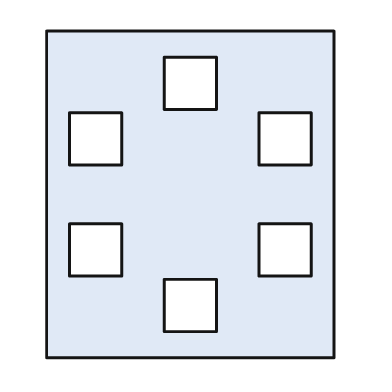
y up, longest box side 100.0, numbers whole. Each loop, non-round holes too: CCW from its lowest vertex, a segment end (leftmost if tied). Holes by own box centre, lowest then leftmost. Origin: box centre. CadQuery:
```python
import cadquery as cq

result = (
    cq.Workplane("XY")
    .moveTo(-44.0, -50.0)
    .lineTo(44.0, -50.0)
    .lineTo(44.0, 50.0)
    .lineTo(-44.0, 50.0)
    .close()
    .moveTo(-8.0, -42.0)
    .lineTo(8.0, -42.0)
    .lineTo(8.0, -26.0)
    .lineTo(-8.0, -26.0)
    .close()
    .moveTo(-37.0, -25.0)
    .lineTo(-21.0, -25.0)
    .lineTo(-21.0, -9.0)
    .lineTo(-37.0, -9.0)
    .close()
    .moveTo(21.0, -25.0)
    .lineTo(37.0, -25.0)
    .lineTo(37.0, -9.0)
    .lineTo(21.0, -9.0)
    .close()
    .moveTo(-37.0, 9.0)
    .lineTo(-21.0, 9.0)
    .lineTo(-21.0, 25.0)
    .lineTo(-37.0, 25.0)
    .close()
    .moveTo(21.0, 9.0)
    .lineTo(37.0, 9.0)
    .lineTo(37.0, 25.0)
    .lineTo(21.0, 25.0)
    .close()
    .moveTo(-8.0, 26.0)
    .lineTo(8.0, 26.0)
    .lineTo(8.0, 42.0)
    .lineTo(-8.0, 42.0)
    .close()
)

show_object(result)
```